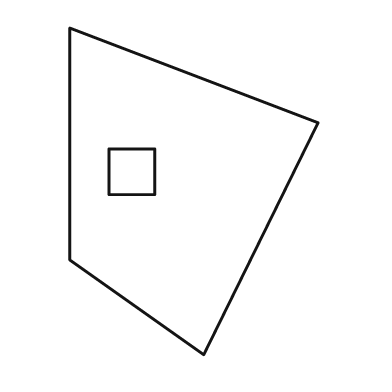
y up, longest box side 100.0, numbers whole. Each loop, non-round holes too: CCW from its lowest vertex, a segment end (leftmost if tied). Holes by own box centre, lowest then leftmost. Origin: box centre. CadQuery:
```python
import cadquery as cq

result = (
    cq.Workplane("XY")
    .moveTo(3.0, -50.0)
    .lineTo(38.0, 21.0)
    .lineTo(-38.0, 50.0)
    .lineTo(-38.0, -21.0)
    .close()
    .moveTo(-26.0, -1.0)
    .lineTo(-12.0, -1.0)
    .lineTo(-12.0, 13.0)
    .lineTo(-26.0, 13.0)
    .close()
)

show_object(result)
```